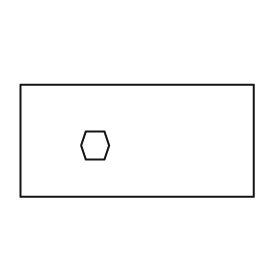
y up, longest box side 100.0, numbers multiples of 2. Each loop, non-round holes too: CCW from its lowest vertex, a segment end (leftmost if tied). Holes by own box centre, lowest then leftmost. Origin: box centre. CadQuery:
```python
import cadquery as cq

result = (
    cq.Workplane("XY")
    .moveTo(-50.0, -24.0)
    .lineTo(50.0, -24.0)
    .lineTo(50.0, 24.0)
    .lineTo(-50.0, 24.0)
    .close()
    .moveTo(-22.0, -8.0)
    .lineTo(-14.0, -8.0)
    .lineTo(-12.0, -2.0)
    .lineTo(-14.0, 4.0)
    .lineTo(-22.0, 4.0)
    .lineTo(-24.0, -2.0)
    .close()
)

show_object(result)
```